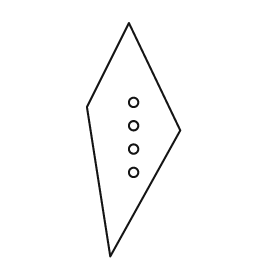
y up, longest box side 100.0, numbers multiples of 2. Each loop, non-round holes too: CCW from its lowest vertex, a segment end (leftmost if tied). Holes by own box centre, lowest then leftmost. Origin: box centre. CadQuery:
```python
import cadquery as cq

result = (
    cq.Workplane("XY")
    .moveTo(-10.0, -50.0)
    .lineTo(20.0, 4.0)
    .lineTo(-2.0, 50.0)
    .lineTo(-20.0, 14.0)
    .close()
    .moveTo(0.0, -14.0)
    .circle(2.0)
    .moveTo(0.0, -4.0)
    .circle(2.0)
    .moveTo(0.0, 6.0)
    .circle(2.0)
    .moveTo(0.0, 16.0)
    .circle(2.0)
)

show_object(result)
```